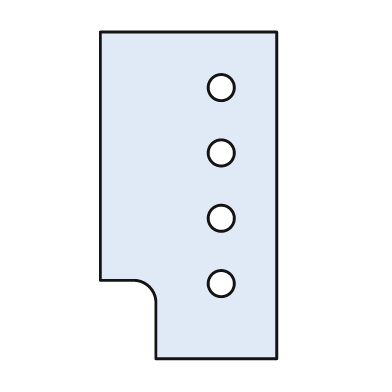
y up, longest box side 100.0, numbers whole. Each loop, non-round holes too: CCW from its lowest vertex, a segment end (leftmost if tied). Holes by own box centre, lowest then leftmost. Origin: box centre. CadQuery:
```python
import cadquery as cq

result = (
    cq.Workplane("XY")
    .moveTo(-10.0, -50.0)
    .lineTo(27.0, -50.0)
    .lineTo(27.0, 50.0)
    .lineTo(-27.0, 50.0)
    .lineTo(-27.0, -26.0)
    .lineTo(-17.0, -26.0)
    .threePointArc((-12.0, -28.0), (-10.0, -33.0))
    .close()
    .moveTo(10.0, -27.0)
    .circle(4.0)
    .moveTo(10.0, -7.0)
    .circle(4.0)
    .moveTo(10.0, 13.0)
    .circle(4.0)
    .moveTo(10.0, 33.0)
    .circle(4.0)
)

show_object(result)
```